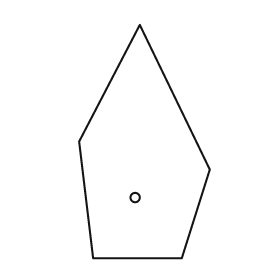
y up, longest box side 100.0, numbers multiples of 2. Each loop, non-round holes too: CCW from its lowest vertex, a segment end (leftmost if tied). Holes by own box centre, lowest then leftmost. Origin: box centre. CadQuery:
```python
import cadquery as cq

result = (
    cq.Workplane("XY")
    .moveTo(-22.0, -50.0)
    .lineTo(16.0, -50.0)
    .lineTo(28.0, -12.0)
    .lineTo(-2.0, 50.0)
    .lineTo(-28.0, 0.0)
    .close()
    .moveTo(-4.0, -24.0)
    .circle(2.0)
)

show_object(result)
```